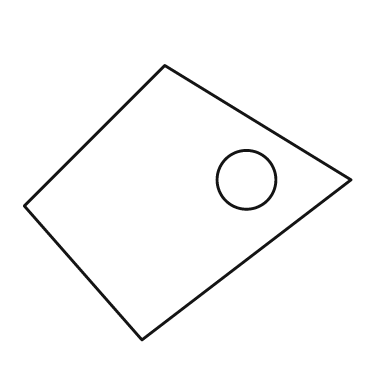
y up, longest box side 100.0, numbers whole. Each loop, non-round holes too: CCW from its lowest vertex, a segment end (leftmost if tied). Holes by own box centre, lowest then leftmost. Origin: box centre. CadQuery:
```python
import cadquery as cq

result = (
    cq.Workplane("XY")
    .moveTo(-14.0, -42.0)
    .lineTo(50.0, 7.0)
    .lineTo(-7.0, 42.0)
    .lineTo(-50.0, -1.0)
    .close()
    .moveTo(18.0, 7.0)
    .circle(9.0)
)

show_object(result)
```